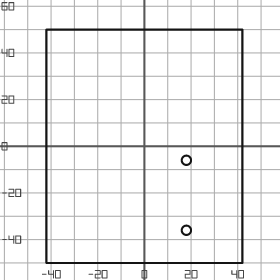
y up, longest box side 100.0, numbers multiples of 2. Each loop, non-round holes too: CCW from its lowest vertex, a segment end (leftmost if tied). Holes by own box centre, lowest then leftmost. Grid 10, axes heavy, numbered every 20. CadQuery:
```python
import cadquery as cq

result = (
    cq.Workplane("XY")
    .moveTo(-42.0, -50.0)
    .lineTo(42.0, -50.0)
    .lineTo(42.0, 50.0)
    .lineTo(-42.0, 50.0)
    .close()
    .moveTo(18.0, -36.0)
    .circle(2.0)
    .moveTo(18.0, -6.0)
    .circle(2.0)
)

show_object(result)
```